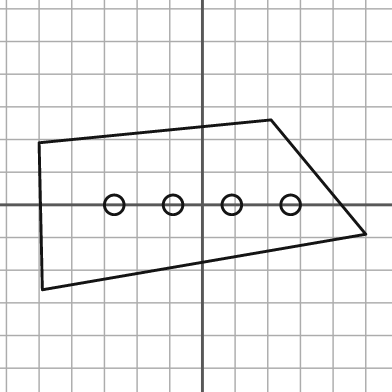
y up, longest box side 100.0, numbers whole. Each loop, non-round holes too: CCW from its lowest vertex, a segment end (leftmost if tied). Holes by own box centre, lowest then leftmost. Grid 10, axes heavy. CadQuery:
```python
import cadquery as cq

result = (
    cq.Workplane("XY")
    .moveTo(-49.0, -26.0)
    .lineTo(50.0, -9.0)
    .lineTo(21.0, 26.0)
    .lineTo(-50.0, 19.0)
    .close()
    .moveTo(-27.0, 0.0)
    .circle(3.0)
    .moveTo(-9.0, 0.0)
    .circle(3.0)
    .moveTo(9.0, 0.0)
    .circle(3.0)
    .moveTo(27.0, 0.0)
    .circle(3.0)
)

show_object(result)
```